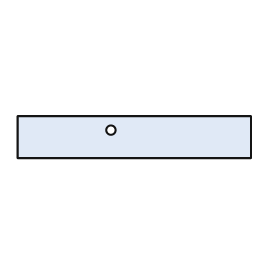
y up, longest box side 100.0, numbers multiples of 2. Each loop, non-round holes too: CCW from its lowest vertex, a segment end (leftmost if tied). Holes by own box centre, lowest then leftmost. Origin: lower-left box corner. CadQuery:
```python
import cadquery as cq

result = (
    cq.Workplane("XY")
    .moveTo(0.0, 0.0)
    .lineTo(100.0, 0.0)
    .lineTo(100.0, 18.0)
    .lineTo(0.0, 18.0)
    .close()
    .moveTo(40.0, 12.0)
    .circle(2.0)
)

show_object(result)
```